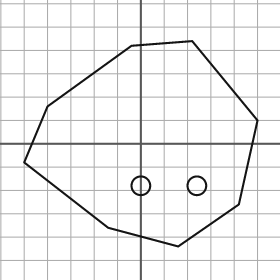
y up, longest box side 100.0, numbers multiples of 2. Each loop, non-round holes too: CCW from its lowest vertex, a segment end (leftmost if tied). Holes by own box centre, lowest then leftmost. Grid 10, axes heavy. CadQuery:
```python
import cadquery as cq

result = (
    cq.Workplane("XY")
    .moveTo(16.0, -44.0)
    .lineTo(42.0, -26.0)
    .lineTo(50.0, 10.0)
    .lineTo(22.0, 44.0)
    .lineTo(-4.0, 42.0)
    .lineTo(-40.0, 16.0)
    .lineTo(-50.0, -8.0)
    .lineTo(-14.0, -36.0)
    .close()
    .moveTo(0.0, -18.0)
    .circle(4.0)
    .moveTo(24.0, -18.0)
    .circle(4.0)
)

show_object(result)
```